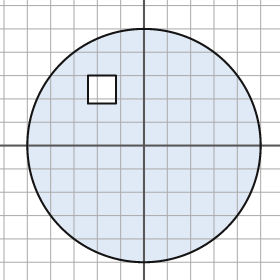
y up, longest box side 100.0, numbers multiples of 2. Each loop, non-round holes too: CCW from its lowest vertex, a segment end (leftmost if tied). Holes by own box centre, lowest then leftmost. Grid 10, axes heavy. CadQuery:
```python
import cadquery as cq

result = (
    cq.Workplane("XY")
    .moveTo(0.0, 0.0)
    .circle(50.0)
    .moveTo(-24.0, 18.0)
    .lineTo(-12.0, 18.0)
    .lineTo(-12.0, 30.0)
    .lineTo(-24.0, 30.0)
    .close()
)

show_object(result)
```